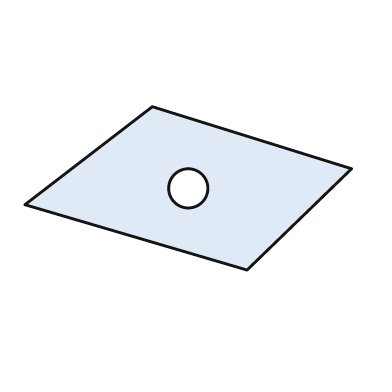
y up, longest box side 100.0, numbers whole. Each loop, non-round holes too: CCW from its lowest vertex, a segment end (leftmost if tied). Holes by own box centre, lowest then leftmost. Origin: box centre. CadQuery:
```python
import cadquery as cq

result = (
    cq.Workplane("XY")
    .moveTo(18.0, -25.0)
    .lineTo(50.0, 6.0)
    .lineTo(-11.0, 25.0)
    .lineTo(-50.0, -5.0)
    .close()
    .moveTo(0.0, 0.0)
    .circle(6.0)
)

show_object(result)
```